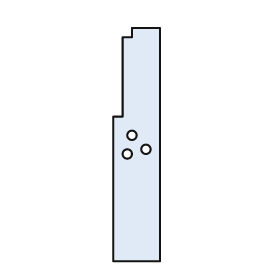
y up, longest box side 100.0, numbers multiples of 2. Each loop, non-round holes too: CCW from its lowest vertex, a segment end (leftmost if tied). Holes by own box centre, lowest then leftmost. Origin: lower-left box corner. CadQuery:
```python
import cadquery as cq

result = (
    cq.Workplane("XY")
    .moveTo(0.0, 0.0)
    .lineTo(20.0, 0.0)
    .lineTo(20.0, 100.0)
    .lineTo(8.0, 100.0)
    .lineTo(8.0, 96.0)
    .lineTo(4.0, 96.0)
    .lineTo(4.0, 62.0)
    .lineTo(0.0, 62.0)
    .close()
    .moveTo(6.0, 46.0)
    .circle(2.0)
    .moveTo(14.0, 48.0)
    .circle(2.0)
    .moveTo(8.0, 54.0)
    .circle(2.0)
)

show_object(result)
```